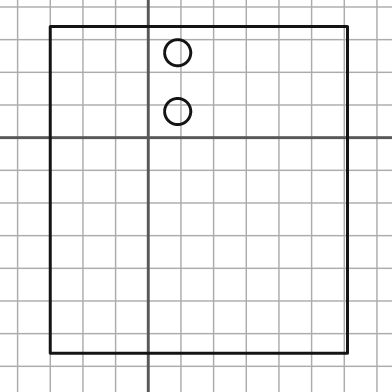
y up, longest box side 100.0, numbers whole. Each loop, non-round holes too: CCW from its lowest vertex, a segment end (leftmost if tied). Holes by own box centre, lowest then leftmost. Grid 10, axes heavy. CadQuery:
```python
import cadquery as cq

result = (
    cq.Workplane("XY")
    .moveTo(-30.0, -66.0)
    .lineTo(61.0, -66.0)
    .lineTo(61.0, 34.0)
    .lineTo(-30.0, 34.0)
    .close()
    .moveTo(9.0, 8.0)
    .circle(4.0)
    .moveTo(9.0, 26.0)
    .circle(4.0)
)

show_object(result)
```